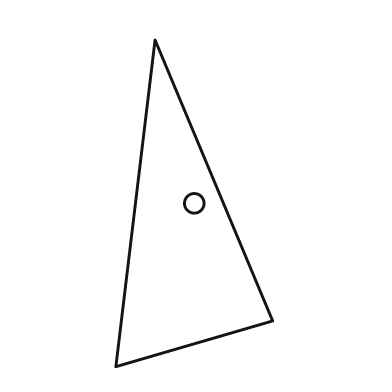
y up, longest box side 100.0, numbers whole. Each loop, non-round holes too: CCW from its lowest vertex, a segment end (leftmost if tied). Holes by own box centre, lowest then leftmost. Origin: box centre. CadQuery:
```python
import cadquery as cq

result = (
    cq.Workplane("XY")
    .moveTo(-24.0, -50.0)
    .lineTo(24.0, -36.0)
    .lineTo(-12.0, 50.0)
    .close()
    .moveTo(0.0, 0.0)
    .circle(3.0)
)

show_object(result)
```